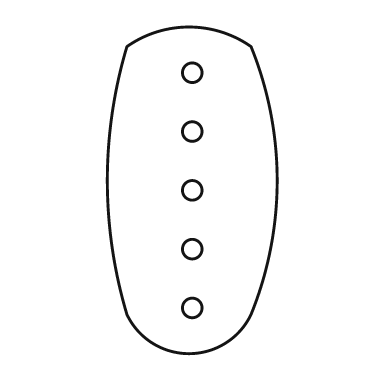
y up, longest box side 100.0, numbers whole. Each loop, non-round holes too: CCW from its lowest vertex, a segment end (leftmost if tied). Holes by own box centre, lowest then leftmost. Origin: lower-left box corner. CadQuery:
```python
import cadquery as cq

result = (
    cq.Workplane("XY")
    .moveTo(6.0, 12.0)
    .threePointArc((25.0, 0.0), (44.0, 12.0))
    .threePointArc((52.0, 53.0), (44.0, 94.0))
    .threePointArc((25.0, 100.0), (6.0, 94.0))
    .threePointArc((0.0, 53.0), (6.0, 12.0))
    .close()
    .moveTo(26.0, 14.0)
    .circle(3.0)
    .moveTo(26.0, 32.0)
    .circle(3.0)
    .moveTo(26.0, 50.0)
    .circle(3.0)
    .moveTo(26.0, 68.0)
    .circle(3.0)
    .moveTo(26.0, 86.0)
    .circle(3.0)
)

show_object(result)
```